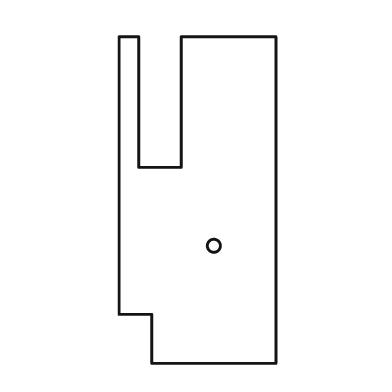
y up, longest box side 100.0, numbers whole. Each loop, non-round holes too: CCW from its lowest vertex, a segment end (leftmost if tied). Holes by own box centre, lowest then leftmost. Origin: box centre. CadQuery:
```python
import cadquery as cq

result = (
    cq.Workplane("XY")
    .moveTo(-14.0, -50.0)
    .lineTo(24.0, -50.0)
    .lineTo(24.0, 50.0)
    .lineTo(-5.0, 50.0)
    .lineTo(-5.0, 10.0)
    .lineTo(-18.0, 10.0)
    .lineTo(-18.0, 50.0)
    .lineTo(-24.0, 50.0)
    .lineTo(-24.0, -35.0)
    .lineTo(-14.0, -35.0)
    .close()
    .moveTo(5.0, -14.0)
    .circle(2.0)
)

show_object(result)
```